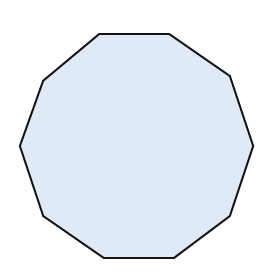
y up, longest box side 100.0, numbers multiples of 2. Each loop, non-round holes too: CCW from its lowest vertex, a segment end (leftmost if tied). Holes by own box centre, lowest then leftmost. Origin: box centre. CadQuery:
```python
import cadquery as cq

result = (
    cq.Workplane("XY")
    .moveTo(-14.0, -48.0)
    .lineTo(16.0, -48.0)
    .lineTo(40.0, -30.0)
    .lineTo(50.0, 0.0)
    .lineTo(40.0, 30.0)
    .lineTo(14.0, 48.0)
    .lineTo(-16.0, 48.0)
    .lineTo(-40.0, 28.0)
    .lineTo(-50.0, 0.0)
    .lineTo(-40.0, -30.0)
    .close()
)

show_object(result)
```